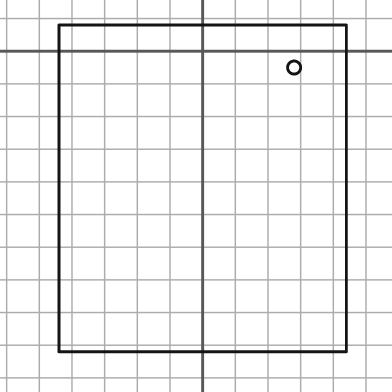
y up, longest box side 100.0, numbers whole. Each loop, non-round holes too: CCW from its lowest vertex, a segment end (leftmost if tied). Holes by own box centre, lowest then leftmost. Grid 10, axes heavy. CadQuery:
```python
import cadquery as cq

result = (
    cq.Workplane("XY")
    .moveTo(-44.0, -92.0)
    .lineTo(44.0, -92.0)
    .lineTo(44.0, 8.0)
    .lineTo(-44.0, 8.0)
    .close()
    .moveTo(28.0, -5.0)
    .circle(2.0)
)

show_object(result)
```